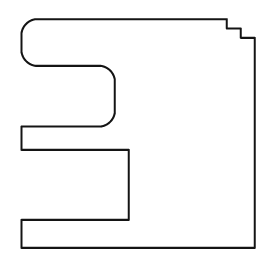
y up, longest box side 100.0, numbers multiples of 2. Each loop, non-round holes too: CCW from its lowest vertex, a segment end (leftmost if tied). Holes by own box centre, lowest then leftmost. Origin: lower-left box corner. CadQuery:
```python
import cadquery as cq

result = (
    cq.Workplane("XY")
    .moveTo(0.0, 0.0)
    .lineTo(100.0, 0.0)
    .lineTo(100.0, 90.0)
    .lineTo(94.0, 90.0)
    .lineTo(94.0, 94.0)
    .lineTo(88.0, 94.0)
    .lineTo(88.0, 98.0)
    .lineTo(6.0, 98.0)
    .threePointArc((2.0, 96.0), (0.0, 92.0))
    .lineTo(0.0, 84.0)
    .threePointArc((2.0, 80.0), (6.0, 78.0))
    .lineTo(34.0, 78.0)
    .threePointArc((38.0, 76.0), (40.0, 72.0))
    .lineTo(40.0, 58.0)
    .threePointArc((38.0, 54.0), (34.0, 52.0))
    .lineTo(0.0, 52.0)
    .lineTo(0.0, 42.0)
    .lineTo(46.0, 42.0)
    .lineTo(46.0, 12.0)
    .lineTo(0.0, 12.0)
    .close()
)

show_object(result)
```